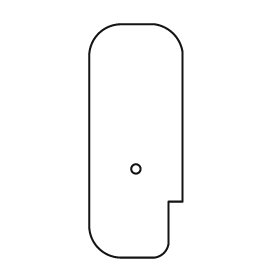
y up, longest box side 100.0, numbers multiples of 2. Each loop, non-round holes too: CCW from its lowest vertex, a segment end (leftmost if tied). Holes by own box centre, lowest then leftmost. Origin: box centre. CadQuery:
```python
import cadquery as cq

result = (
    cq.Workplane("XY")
    .moveTo(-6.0, -50.0)
    .lineTo(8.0, -50.0)
    .threePointArc((12.0, -48.0), (14.0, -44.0))
    .lineTo(14.0, -26.0)
    .lineTo(20.0, -26.0)
    .lineTo(20.0, 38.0)
    .threePointArc((16.0, 46.0), (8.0, 50.0))
    .lineTo(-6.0, 50.0)
    .threePointArc((-16.0, 46.0), (-20.0, 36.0))
    .lineTo(-20.0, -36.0)
    .threePointArc((-16.0, -46.0), (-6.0, -50.0))
    .close()
    .moveTo(0.0, -12.0)
    .circle(2.0)
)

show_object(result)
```